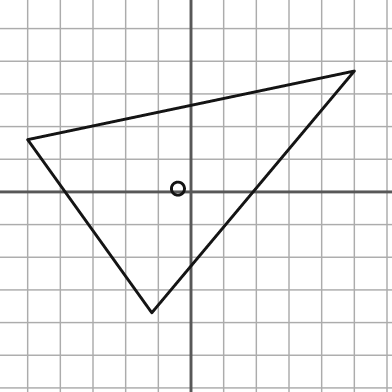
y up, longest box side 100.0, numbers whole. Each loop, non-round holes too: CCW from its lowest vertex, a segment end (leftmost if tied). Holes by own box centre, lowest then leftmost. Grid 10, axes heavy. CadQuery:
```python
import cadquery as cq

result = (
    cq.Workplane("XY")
    .moveTo(-12.0, -37.0)
    .lineTo(50.0, 37.0)
    .lineTo(-50.0, 16.0)
    .close()
    .moveTo(-4.0, 1.0)
    .circle(2.0)
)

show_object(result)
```